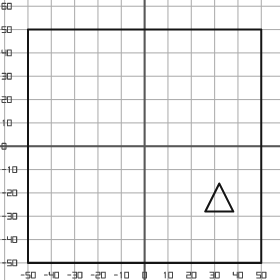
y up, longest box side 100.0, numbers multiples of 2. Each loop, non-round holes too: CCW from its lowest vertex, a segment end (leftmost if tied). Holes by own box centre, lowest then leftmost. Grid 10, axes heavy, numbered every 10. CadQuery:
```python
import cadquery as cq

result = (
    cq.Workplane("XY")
    .moveTo(-50.0, -50.0)
    .lineTo(50.0, -50.0)
    .lineTo(50.0, 50.0)
    .lineTo(-50.0, 50.0)
    .close()
    .moveTo(26.0, -28.0)
    .lineTo(38.0, -28.0)
    .lineTo(32.0, -16.0)
    .close()
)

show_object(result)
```